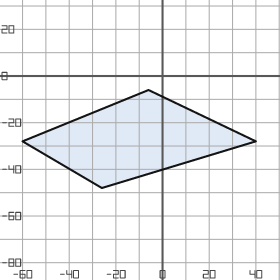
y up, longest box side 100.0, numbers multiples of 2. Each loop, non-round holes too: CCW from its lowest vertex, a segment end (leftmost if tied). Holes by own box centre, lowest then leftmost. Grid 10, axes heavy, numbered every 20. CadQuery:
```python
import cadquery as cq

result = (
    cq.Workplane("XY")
    .moveTo(-26.0, -48.0)
    .lineTo(40.0, -28.0)
    .lineTo(-6.0, -6.0)
    .lineTo(-60.0, -28.0)
    .close()
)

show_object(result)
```